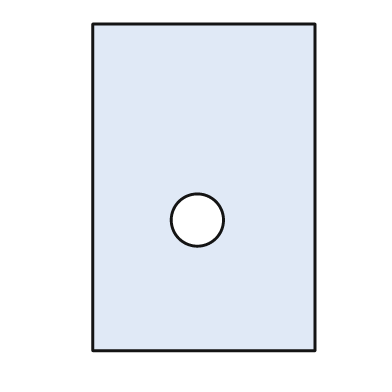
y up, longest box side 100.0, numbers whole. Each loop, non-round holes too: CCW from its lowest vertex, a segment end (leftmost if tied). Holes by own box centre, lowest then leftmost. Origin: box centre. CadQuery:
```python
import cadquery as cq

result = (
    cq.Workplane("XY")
    .moveTo(-34.0, -50.0)
    .lineTo(34.0, -50.0)
    .lineTo(34.0, 50.0)
    .lineTo(-34.0, 50.0)
    .close()
    .moveTo(-2.0, -10.0)
    .circle(8.0)
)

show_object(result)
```